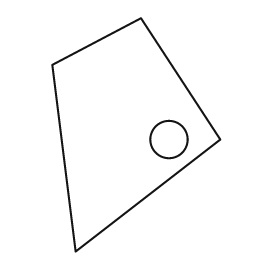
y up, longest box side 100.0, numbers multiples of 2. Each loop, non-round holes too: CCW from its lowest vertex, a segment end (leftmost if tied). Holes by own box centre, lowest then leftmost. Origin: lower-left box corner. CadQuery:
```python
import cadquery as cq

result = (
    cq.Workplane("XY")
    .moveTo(10.0, 0.0)
    .lineTo(72.0, 48.0)
    .lineTo(38.0, 100.0)
    .lineTo(0.0, 80.0)
    .close()
    .moveTo(50.0, 48.0)
    .circle(8.0)
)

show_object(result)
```